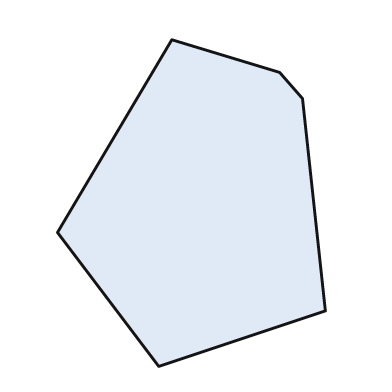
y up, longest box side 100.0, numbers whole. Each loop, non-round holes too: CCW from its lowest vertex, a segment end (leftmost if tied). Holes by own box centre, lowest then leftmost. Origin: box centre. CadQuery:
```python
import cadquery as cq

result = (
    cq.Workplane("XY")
    .moveTo(-10.0, -50.0)
    .lineTo(41.0, -33.0)
    .lineTo(34.0, 32.0)
    .lineTo(27.0, 40.0)
    .lineTo(-6.0, 50.0)
    .lineTo(-41.0, -9.0)
    .close()
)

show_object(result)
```